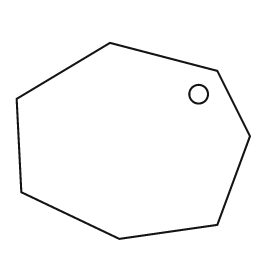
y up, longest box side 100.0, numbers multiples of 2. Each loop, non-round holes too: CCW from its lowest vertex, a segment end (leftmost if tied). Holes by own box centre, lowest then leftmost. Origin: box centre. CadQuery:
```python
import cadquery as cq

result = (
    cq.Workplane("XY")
    .moveTo(-6.0, -42.0)
    .lineTo(36.0, -36.0)
    .lineTo(50.0, 2.0)
    .lineTo(36.0, 30.0)
    .lineTo(-10.0, 42.0)
    .lineTo(-50.0, 18.0)
    .lineTo(-48.0, -22.0)
    .close()
    .moveTo(28.0, 20.0)
    .circle(4.0)
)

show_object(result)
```